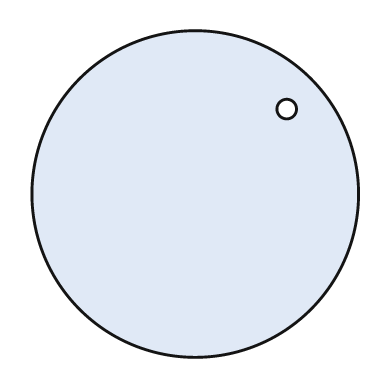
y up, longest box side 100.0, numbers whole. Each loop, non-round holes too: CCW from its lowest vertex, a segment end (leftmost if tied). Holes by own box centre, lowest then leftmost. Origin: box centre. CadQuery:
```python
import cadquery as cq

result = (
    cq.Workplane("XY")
    .moveTo(0.0, 0.0)
    .circle(50.0)
    .moveTo(28.0, 26.0)
    .circle(3.0)
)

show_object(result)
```